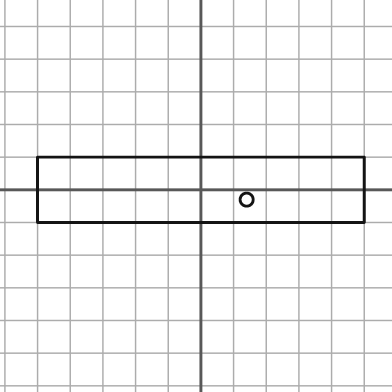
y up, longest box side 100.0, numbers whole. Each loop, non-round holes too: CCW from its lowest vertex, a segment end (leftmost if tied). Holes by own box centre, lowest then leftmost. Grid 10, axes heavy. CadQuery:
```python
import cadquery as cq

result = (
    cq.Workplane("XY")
    .moveTo(-50.0, -10.0)
    .lineTo(50.0, -10.0)
    .lineTo(50.0, 10.0)
    .lineTo(-50.0, 10.0)
    .close()
    .moveTo(14.0, -3.0)
    .circle(2.0)
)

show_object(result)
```